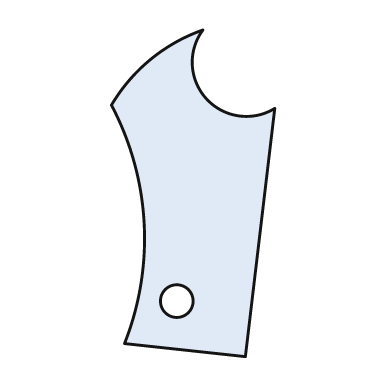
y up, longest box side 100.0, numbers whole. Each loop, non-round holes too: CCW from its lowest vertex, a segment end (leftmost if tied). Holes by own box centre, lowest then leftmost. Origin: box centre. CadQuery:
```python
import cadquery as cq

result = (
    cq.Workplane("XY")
    .moveTo(16.0, -50.0)
    .lineTo(25.0, 26.0)
    .threePointArc((4.0, 29.0), (3.0, 50.0))
    .threePointArc((-13.0, 41.0), (-25.0, 27.0))
    .threePointArc((-15.0, -9.0), (-21.0, -46.0))
    .close()
    .moveTo(-5.0, -33.0)
    .circle(5.0)
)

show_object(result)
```